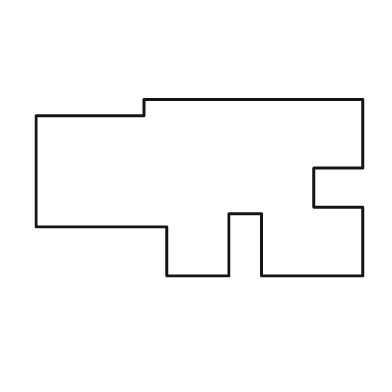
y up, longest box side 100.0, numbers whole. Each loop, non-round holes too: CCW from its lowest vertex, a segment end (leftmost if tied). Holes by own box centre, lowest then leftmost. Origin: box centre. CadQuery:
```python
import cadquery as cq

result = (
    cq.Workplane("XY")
    .moveTo(-10.0, -27.0)
    .lineTo(9.0, -27.0)
    .lineTo(9.0, -8.0)
    .lineTo(19.0, -8.0)
    .lineTo(19.0, -27.0)
    .lineTo(50.0, -27.0)
    .lineTo(50.0, -6.0)
    .lineTo(35.0, -6.0)
    .lineTo(35.0, 6.0)
    .lineTo(50.0, 6.0)
    .lineTo(50.0, 27.0)
    .lineTo(-17.0, 27.0)
    .lineTo(-17.0, 22.0)
    .lineTo(-50.0, 22.0)
    .lineTo(-50.0, -12.0)
    .lineTo(-10.0, -12.0)
    .close()
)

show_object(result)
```